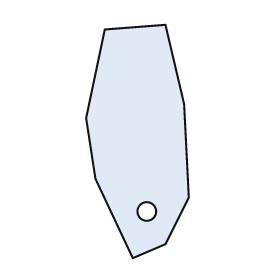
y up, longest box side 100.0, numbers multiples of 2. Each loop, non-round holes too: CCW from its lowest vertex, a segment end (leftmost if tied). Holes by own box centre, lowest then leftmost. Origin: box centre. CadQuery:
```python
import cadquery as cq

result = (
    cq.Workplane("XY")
    .moveTo(-2.0, -50.0)
    .lineTo(12.0, -44.0)
    .lineTo(22.0, -24.0)
    .lineTo(20.0, 16.0)
    .lineTo(12.0, 50.0)
    .lineTo(-14.0, 48.0)
    .lineTo(-22.0, 10.0)
    .lineTo(-18.0, -16.0)
    .close()
    .moveTo(4.0, -30.0)
    .circle(4.0)
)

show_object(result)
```